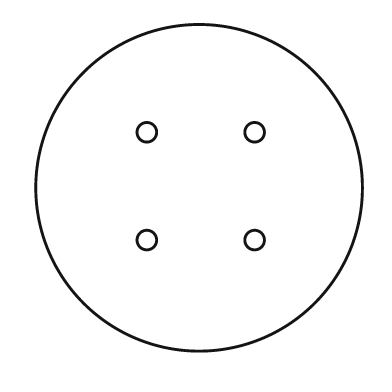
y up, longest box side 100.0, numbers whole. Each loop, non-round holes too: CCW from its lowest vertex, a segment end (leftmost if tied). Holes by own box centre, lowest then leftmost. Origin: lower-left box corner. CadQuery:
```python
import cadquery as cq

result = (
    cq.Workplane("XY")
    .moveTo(50.0, 50.0)
    .circle(50.0)
    .moveTo(34.0, 34.0)
    .circle(3.0)
    .moveTo(67.0, 34.0)
    .circle(3.0)
    .moveTo(34.0, 67.0)
    .circle(3.0)
    .moveTo(67.0, 67.0)
    .circle(3.0)
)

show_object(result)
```